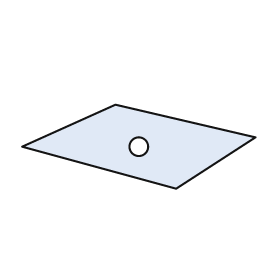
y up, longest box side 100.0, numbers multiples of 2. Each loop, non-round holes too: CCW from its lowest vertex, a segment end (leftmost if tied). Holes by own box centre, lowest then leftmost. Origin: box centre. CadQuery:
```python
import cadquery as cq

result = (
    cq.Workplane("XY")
    .moveTo(16.0, -18.0)
    .lineTo(50.0, 4.0)
    .lineTo(-10.0, 18.0)
    .lineTo(-50.0, 0.0)
    .close()
    .moveTo(0.0, 0.0)
    .circle(4.0)
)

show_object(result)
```